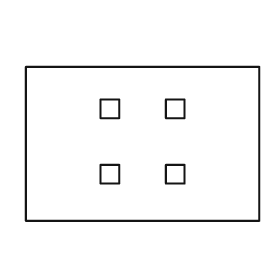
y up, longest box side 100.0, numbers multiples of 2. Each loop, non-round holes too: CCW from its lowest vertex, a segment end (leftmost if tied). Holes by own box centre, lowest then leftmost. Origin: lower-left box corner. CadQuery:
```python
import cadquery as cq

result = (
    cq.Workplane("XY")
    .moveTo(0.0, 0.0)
    .lineTo(100.0, 0.0)
    .lineTo(100.0, 66.0)
    .lineTo(0.0, 66.0)
    .close()
    .moveTo(32.0, 16.0)
    .lineTo(40.0, 16.0)
    .lineTo(40.0, 24.0)
    .lineTo(32.0, 24.0)
    .close()
    .moveTo(60.0, 16.0)
    .lineTo(68.0, 16.0)
    .lineTo(68.0, 24.0)
    .lineTo(60.0, 24.0)
    .close()
    .moveTo(32.0, 44.0)
    .lineTo(40.0, 44.0)
    .lineTo(40.0, 52.0)
    .lineTo(32.0, 52.0)
    .close()
    .moveTo(60.0, 44.0)
    .lineTo(68.0, 44.0)
    .lineTo(68.0, 52.0)
    .lineTo(60.0, 52.0)
    .close()
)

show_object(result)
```